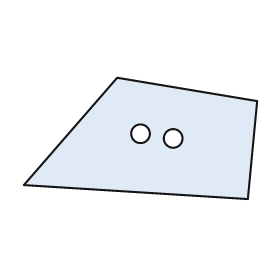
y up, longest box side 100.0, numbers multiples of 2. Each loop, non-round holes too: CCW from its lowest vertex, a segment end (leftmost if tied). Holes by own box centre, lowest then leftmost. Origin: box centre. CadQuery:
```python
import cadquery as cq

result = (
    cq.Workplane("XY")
    .moveTo(46.0, -26.0)
    .lineTo(50.0, 16.0)
    .lineTo(-10.0, 26.0)
    .lineTo(-50.0, -20.0)
    .close()
    .moveTo(14.0, 0.0)
    .circle(4.0)
    .moveTo(0.0, 2.0)
    .circle(4.0)
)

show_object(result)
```